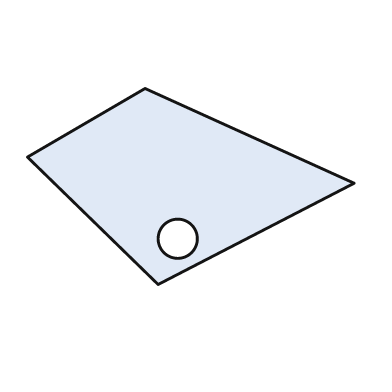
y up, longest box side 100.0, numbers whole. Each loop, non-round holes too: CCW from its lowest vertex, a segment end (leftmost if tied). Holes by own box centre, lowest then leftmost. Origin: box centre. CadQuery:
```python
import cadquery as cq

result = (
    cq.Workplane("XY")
    .moveTo(-10.0, -30.0)
    .lineTo(50.0, 1.0)
    .lineTo(-14.0, 30.0)
    .lineTo(-50.0, 9.0)
    .close()
    .moveTo(-4.0, -16.0)
    .circle(6.0)
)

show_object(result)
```